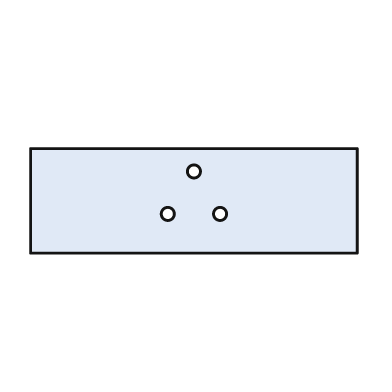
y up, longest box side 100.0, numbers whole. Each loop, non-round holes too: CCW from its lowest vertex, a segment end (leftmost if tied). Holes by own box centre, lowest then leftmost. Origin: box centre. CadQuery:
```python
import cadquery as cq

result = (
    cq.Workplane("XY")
    .moveTo(-50.0, -16.0)
    .lineTo(50.0, -16.0)
    .lineTo(50.0, 16.0)
    .lineTo(-50.0, 16.0)
    .close()
    .moveTo(-8.0, -4.0)
    .circle(2.0)
    .moveTo(8.0, -4.0)
    .circle(2.0)
    .moveTo(0.0, 9.0)
    .circle(2.0)
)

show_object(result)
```